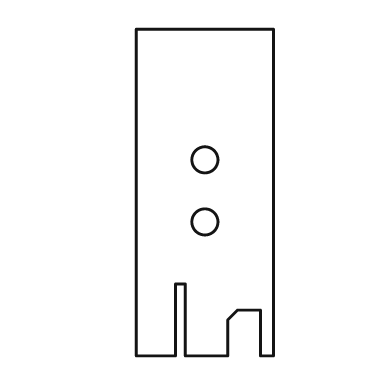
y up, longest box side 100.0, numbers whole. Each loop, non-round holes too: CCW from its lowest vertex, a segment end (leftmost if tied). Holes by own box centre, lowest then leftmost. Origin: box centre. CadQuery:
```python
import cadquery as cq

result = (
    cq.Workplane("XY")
    .moveTo(-21.0, -50.0)
    .lineTo(-9.0, -50.0)
    .lineTo(-9.0, -28.0)
    .lineTo(-6.0, -28.0)
    .lineTo(-6.0, -50.0)
    .lineTo(7.0, -50.0)
    .lineTo(7.0, -39.0)
    .lineTo(10.0, -36.0)
    .lineTo(17.0, -36.0)
    .lineTo(17.0, -50.0)
    .lineTo(21.0, -50.0)
    .lineTo(21.0, 50.0)
    .lineTo(-21.0, 50.0)
    .close()
    .moveTo(0.0, -9.0)
    .circle(4.0)
    .moveTo(0.0, 10.0)
    .circle(4.0)
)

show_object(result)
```